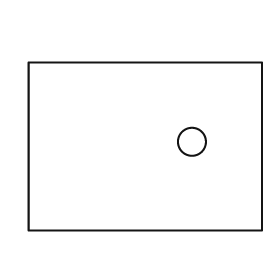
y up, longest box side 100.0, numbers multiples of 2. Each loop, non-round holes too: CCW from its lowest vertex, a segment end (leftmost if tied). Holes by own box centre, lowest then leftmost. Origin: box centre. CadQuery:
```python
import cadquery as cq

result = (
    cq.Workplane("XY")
    .moveTo(-50.0, -36.0)
    .lineTo(50.0, -36.0)
    .lineTo(50.0, 36.0)
    .lineTo(-50.0, 36.0)
    .close()
    .moveTo(20.0, 2.0)
    .circle(6.0)
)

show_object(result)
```